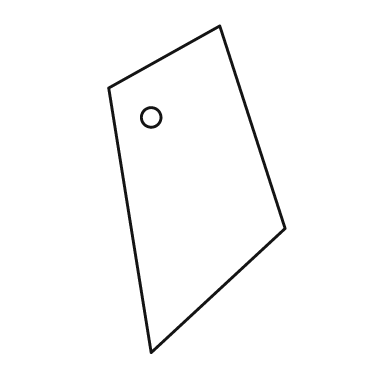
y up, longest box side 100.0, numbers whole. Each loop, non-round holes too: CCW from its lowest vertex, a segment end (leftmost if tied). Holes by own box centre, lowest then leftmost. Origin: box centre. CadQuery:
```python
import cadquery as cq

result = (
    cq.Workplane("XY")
    .moveTo(-14.0, -50.0)
    .lineTo(27.0, -12.0)
    .lineTo(7.0, 50.0)
    .lineTo(-27.0, 31.0)
    .close()
    .moveTo(-14.0, 22.0)
    .circle(3.0)
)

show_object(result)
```